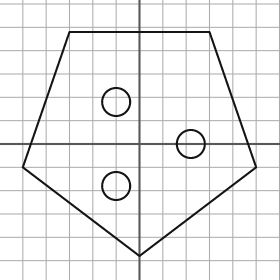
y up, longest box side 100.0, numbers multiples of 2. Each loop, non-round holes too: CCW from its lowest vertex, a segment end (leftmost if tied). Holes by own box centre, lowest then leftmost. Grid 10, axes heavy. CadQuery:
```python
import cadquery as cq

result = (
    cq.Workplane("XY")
    .moveTo(0.0, -48.0)
    .lineTo(50.0, -10.0)
    .lineTo(30.0, 48.0)
    .lineTo(-30.0, 48.0)
    .lineTo(-50.0, -10.0)
    .close()
    .moveTo(-10.0, -18.0)
    .circle(6.0)
    .moveTo(22.0, 0.0)
    .circle(6.0)
    .moveTo(-10.0, 18.0)
    .circle(6.0)
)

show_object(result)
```